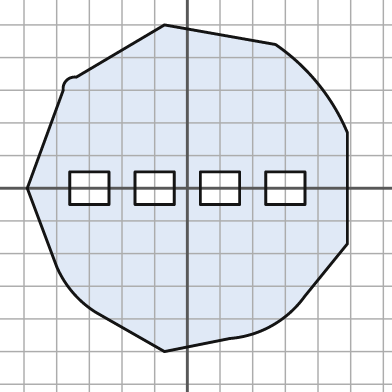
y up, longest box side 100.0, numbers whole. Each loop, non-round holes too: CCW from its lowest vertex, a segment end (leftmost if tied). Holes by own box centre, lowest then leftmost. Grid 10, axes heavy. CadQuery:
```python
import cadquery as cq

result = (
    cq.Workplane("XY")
    .moveTo(-7.0, -50.0)
    .lineTo(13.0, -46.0)
    .threePointArc((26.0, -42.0), (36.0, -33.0))
    .lineTo(49.0, -17.0)
    .lineTo(49.0, 17.0)
    .threePointArc((40.0, 32.0), (27.0, 44.0))
    .lineTo(-7.0, 50.0)
    .lineTo(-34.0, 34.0)
    .threePointArc((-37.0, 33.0), (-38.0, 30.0))
    .lineTo(-49.0, 0.0)
    .lineTo(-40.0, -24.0)
    .threePointArc((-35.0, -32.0), (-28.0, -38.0))
    .close()
    .moveTo(-36.0, -5.0)
    .lineTo(-24.0, -5.0)
    .lineTo(-24.0, 5.0)
    .lineTo(-36.0, 5.0)
    .close()
    .moveTo(-16.0, -5.0)
    .lineTo(-4.0, -5.0)
    .lineTo(-4.0, 5.0)
    .lineTo(-16.0, 5.0)
    .close()
    .moveTo(4.0, -5.0)
    .lineTo(16.0, -5.0)
    .lineTo(16.0, 5.0)
    .lineTo(4.0, 5.0)
    .close()
    .moveTo(24.0, -5.0)
    .lineTo(36.0, -5.0)
    .lineTo(36.0, 5.0)
    .lineTo(24.0, 5.0)
    .close()
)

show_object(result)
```